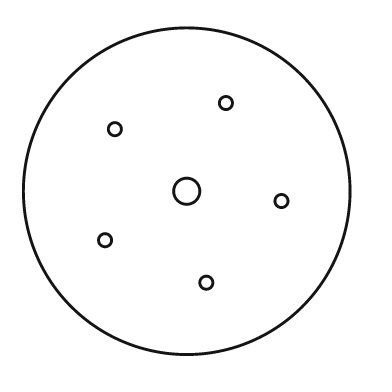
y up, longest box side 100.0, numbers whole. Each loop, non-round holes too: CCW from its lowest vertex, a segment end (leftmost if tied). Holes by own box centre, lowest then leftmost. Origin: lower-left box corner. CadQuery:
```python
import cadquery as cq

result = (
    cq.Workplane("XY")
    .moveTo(50.0, 50.0)
    .circle(50.0)
    .moveTo(56.0, 22.0)
    .circle(2.0)
    .moveTo(25.0, 35.0)
    .circle(2.0)
    .moveTo(79.0, 47.0)
    .circle(2.0)
    .moveTo(50.0, 50.0)
    .circle(4.0)
    .moveTo(28.0, 69.0)
    .circle(2.0)
    .moveTo(62.0, 77.0)
    .circle(2.0)
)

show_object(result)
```